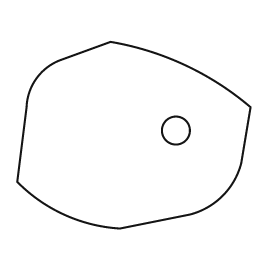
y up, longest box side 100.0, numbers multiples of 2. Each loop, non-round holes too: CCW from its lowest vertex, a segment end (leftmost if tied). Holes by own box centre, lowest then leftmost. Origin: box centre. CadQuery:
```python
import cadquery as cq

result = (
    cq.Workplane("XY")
    .moveTo(-6.0, -40.0)
    .lineTo(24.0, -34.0)
    .threePointArc((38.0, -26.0), (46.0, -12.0))
    .lineTo(50.0, 12.0)
    .threePointArc((22.0, 30.0), (-10.0, 40.0))
    .lineTo(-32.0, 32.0)
    .threePointArc((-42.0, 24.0), (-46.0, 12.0))
    .lineTo(-50.0, -20.0)
    .threePointArc((-30.0, -34.0), (-6.0, -40.0))
    .close()
    .moveTo(18.0, 2.0)
    .circle(6.0)
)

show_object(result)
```